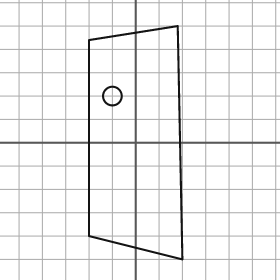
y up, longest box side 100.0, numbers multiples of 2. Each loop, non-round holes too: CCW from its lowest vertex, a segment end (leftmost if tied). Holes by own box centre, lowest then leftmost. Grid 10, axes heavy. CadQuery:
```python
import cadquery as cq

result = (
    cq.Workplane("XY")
    .moveTo(20.0, -50.0)
    .lineTo(18.0, 50.0)
    .lineTo(-20.0, 44.0)
    .lineTo(-20.0, -40.0)
    .close()
    .moveTo(-10.0, 20.0)
    .circle(4.0)
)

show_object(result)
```